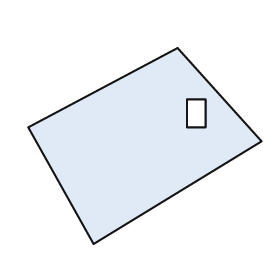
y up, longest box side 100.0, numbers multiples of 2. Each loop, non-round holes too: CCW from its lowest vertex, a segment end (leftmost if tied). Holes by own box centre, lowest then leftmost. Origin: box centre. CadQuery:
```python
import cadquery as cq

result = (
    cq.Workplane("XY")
    .moveTo(-22.0, -42.0)
    .lineTo(50.0, 2.0)
    .lineTo(14.0, 42.0)
    .lineTo(-50.0, 8.0)
    .close()
    .moveTo(18.0, 8.0)
    .lineTo(26.0, 8.0)
    .lineTo(26.0, 20.0)
    .lineTo(18.0, 20.0)
    .close()
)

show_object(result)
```